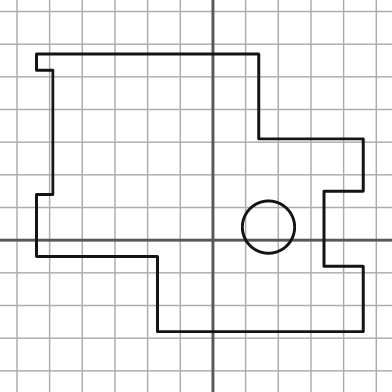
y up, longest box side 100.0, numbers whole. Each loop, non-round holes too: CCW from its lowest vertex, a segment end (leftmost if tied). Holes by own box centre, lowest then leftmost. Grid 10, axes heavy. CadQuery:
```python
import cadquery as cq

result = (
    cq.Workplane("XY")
    .moveTo(-17.0, -28.0)
    .lineTo(46.0, -28.0)
    .lineTo(46.0, -8.0)
    .lineTo(34.0, -8.0)
    .lineTo(34.0, 15.0)
    .lineTo(46.0, 15.0)
    .lineTo(46.0, 31.0)
    .lineTo(14.0, 31.0)
    .lineTo(14.0, 57.0)
    .lineTo(-54.0, 57.0)
    .lineTo(-54.0, 52.0)
    .lineTo(-49.0, 52.0)
    .lineTo(-49.0, 14.0)
    .lineTo(-54.0, 14.0)
    .lineTo(-54.0, -5.0)
    .lineTo(-17.0, -5.0)
    .close()
    .moveTo(17.0, 4.0)
    .circle(8.0)
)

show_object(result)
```